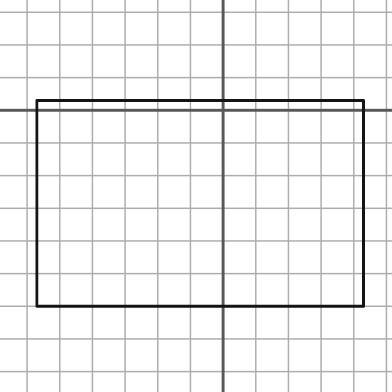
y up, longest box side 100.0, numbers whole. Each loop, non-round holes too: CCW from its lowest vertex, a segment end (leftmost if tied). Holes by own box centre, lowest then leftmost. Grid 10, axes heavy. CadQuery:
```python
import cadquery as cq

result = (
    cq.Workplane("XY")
    .moveTo(-57.0, -60.0)
    .lineTo(43.0, -60.0)
    .lineTo(43.0, 3.0)
    .lineTo(-57.0, 3.0)
    .close()
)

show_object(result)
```